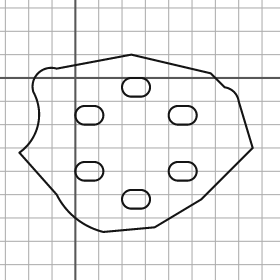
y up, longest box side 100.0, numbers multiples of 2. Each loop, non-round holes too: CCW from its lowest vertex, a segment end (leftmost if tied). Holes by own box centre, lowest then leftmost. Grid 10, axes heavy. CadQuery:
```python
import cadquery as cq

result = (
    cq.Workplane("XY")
    .moveTo(12.0, -66.0)
    .lineTo(34.0, -64.0)
    .lineTo(54.0, -52.0)
    .lineTo(76.0, -30.0)
    .lineTo(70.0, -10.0)
    .threePointArc((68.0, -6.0), (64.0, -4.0))
    .lineTo(58.0, 2.0)
    .lineTo(24.0, 10.0)
    .lineTo(-8.0, 4.0)
    .threePointArc((-16.0, 2.0), (-18.0, -6.0))
    .threePointArc((-16.0, -20.0), (-24.0, -32.0))
    .lineTo(-8.0, -50.0)
    .threePointArc((0.0, -60.0), (12.0, -66.0))
    .close()
    .moveTo(24.0, -56.0)
    .lineTo(28.0, -56.0)
    .threePointArc((32.0, -52.0), (28.0, -48.0))
    .lineTo(24.0, -48.0)
    .threePointArc((20.0, -52.0), (24.0, -56.0))
    .close()
    .moveTo(4.0, -44.0)
    .lineTo(8.0, -44.0)
    .threePointArc((12.0, -40.0), (8.0, -36.0))
    .lineTo(4.0, -36.0)
    .threePointArc((0.0, -40.0), (4.0, -44.0))
    .close()
    .moveTo(44.0, -44.0)
    .lineTo(48.0, -44.0)
    .threePointArc((52.0, -40.0), (48.0, -36.0))
    .lineTo(44.0, -36.0)
    .threePointArc((40.0, -40.0), (44.0, -44.0))
    .close()
    .moveTo(4.0, -20.0)
    .lineTo(8.0, -20.0)
    .threePointArc((12.0, -16.0), (8.0, -12.0))
    .lineTo(4.0, -12.0)
    .threePointArc((0.0, -16.0), (4.0, -20.0))
    .close()
    .moveTo(44.0, -20.0)
    .lineTo(48.0, -20.0)
    .threePointArc((52.0, -16.0), (48.0, -12.0))
    .lineTo(44.0, -12.0)
    .threePointArc((40.0, -16.0), (44.0, -20.0))
    .close()
    .moveTo(24.0, -8.0)
    .lineTo(28.0, -8.0)
    .threePointArc((32.0, -4.0), (28.0, 0.0))
    .lineTo(24.0, 0.0)
    .threePointArc((20.0, -4.0), (24.0, -8.0))
    .close()
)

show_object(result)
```